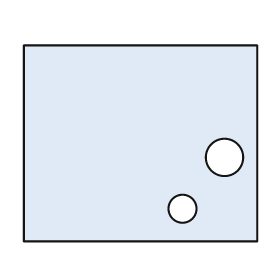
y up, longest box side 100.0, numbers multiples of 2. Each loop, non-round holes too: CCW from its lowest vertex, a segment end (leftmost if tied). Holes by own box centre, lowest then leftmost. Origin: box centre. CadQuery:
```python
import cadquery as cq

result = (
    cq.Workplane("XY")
    .moveTo(-50.0, -42.0)
    .lineTo(50.0, -42.0)
    .lineTo(50.0, 42.0)
    .lineTo(-50.0, 42.0)
    .close()
    .moveTo(18.0, -28.0)
    .circle(6.0)
    .moveTo(36.0, -6.0)
    .circle(8.0)
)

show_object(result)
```